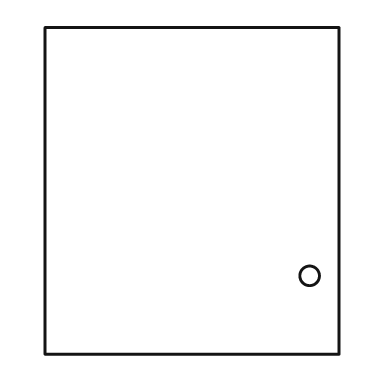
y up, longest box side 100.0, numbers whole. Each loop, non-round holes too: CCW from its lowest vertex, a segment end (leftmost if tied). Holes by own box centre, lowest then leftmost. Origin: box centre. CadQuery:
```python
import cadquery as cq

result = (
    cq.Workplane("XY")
    .moveTo(-45.0, -50.0)
    .lineTo(45.0, -50.0)
    .lineTo(45.0, 50.0)
    .lineTo(-45.0, 50.0)
    .close()
    .moveTo(36.0, -26.0)
    .circle(3.0)
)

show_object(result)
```